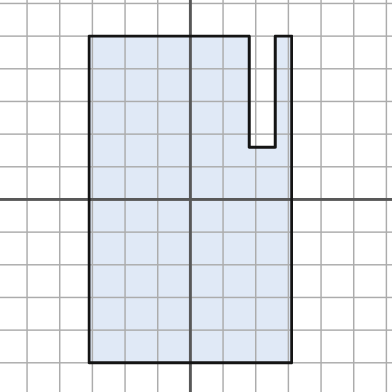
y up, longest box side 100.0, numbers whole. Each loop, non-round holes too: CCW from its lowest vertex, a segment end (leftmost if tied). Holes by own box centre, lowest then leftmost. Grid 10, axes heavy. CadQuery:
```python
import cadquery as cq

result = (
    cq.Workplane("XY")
    .moveTo(-31.0, -50.0)
    .lineTo(31.0, -50.0)
    .lineTo(31.0, 50.0)
    .lineTo(26.0, 50.0)
    .lineTo(26.0, 16.0)
    .lineTo(18.0, 16.0)
    .lineTo(18.0, 50.0)
    .lineTo(-31.0, 50.0)
    .close()
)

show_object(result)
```